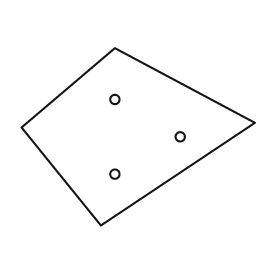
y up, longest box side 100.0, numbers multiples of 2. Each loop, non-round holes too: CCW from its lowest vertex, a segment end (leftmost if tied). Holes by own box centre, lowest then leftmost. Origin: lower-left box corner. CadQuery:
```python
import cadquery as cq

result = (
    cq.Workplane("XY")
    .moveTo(34.0, 0.0)
    .lineTo(100.0, 44.0)
    .lineTo(40.0, 76.0)
    .lineTo(0.0, 42.0)
    .close()
    .moveTo(40.0, 22.0)
    .circle(2.0)
    .moveTo(68.0, 38.0)
    .circle(2.0)
    .moveTo(40.0, 54.0)
    .circle(2.0)
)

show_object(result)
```